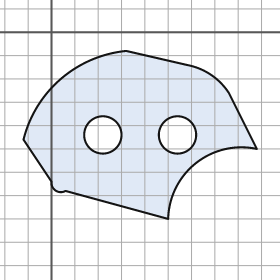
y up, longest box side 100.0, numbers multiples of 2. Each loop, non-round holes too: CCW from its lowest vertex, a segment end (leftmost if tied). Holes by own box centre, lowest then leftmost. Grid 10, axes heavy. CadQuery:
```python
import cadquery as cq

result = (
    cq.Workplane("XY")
    .moveTo(50.0, -80.0)
    .threePointArc((62.0, -56.0), (88.0, -50.0))
    .lineTo(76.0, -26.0)
    .threePointArc((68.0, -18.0), (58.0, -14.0))
    .lineTo(32.0, -8.0)
    .threePointArc((4.0, -20.0), (-12.0, -46.0))
    .lineTo(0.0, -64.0)
    .threePointArc((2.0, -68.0), (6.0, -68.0))
    .close()
    .moveTo(22.0, -44.0)
    .circle(8.0)
    .moveTo(54.0, -44.0)
    .circle(8.0)
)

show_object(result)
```